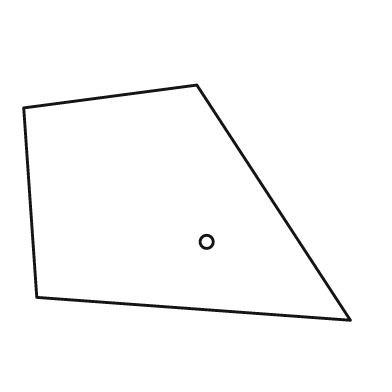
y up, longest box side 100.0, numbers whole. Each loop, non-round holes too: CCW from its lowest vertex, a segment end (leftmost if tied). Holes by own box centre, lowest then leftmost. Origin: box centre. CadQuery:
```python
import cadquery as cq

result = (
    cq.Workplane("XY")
    .moveTo(50.0, -36.0)
    .lineTo(3.0, 36.0)
    .lineTo(-50.0, 29.0)
    .lineTo(-46.0, -29.0)
    .close()
    .moveTo(6.0, -12.0)
    .circle(2.0)
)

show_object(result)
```